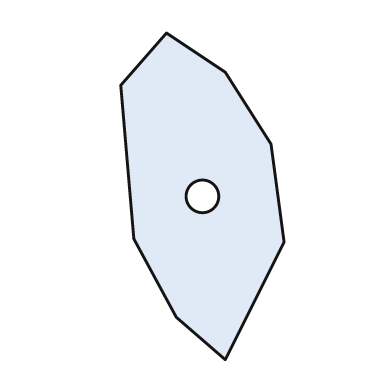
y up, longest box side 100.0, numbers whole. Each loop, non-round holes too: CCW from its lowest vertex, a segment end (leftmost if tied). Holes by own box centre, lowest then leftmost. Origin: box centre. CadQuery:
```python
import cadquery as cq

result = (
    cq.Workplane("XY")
    .moveTo(7.0, -50.0)
    .lineTo(25.0, -14.0)
    .lineTo(21.0, 16.0)
    .lineTo(7.0, 38.0)
    .lineTo(-11.0, 50.0)
    .lineTo(-25.0, 34.0)
    .lineTo(-21.0, -13.0)
    .lineTo(-8.0, -37.0)
    .close()
    .moveTo(0.0, 0.0)
    .circle(5.0)
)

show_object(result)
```